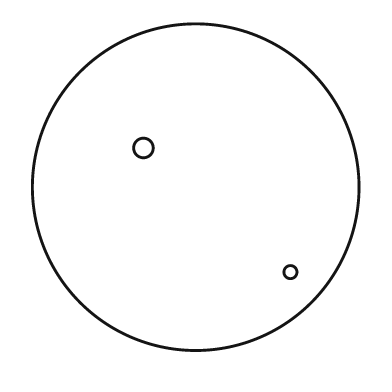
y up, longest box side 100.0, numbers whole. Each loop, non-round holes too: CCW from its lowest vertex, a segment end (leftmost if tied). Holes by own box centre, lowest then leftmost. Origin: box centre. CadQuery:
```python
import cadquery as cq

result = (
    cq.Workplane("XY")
    .moveTo(0.0, 0.0)
    .circle(50.0)
    .moveTo(29.0, -26.0)
    .circle(2.0)
    .moveTo(-16.0, 12.0)
    .circle(3.0)
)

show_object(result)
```